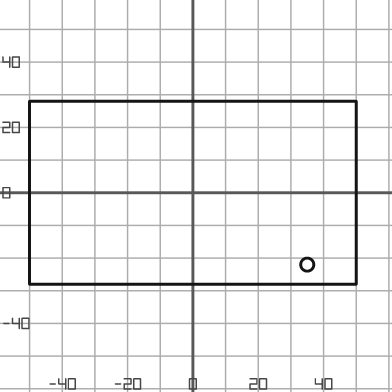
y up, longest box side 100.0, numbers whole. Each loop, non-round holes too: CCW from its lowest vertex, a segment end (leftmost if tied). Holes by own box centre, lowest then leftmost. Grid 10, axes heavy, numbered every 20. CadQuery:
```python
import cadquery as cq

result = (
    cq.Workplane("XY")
    .moveTo(-50.0, -28.0)
    .lineTo(50.0, -28.0)
    .lineTo(50.0, 28.0)
    .lineTo(-50.0, 28.0)
    .close()
    .moveTo(35.0, -22.0)
    .circle(2.0)
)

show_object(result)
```